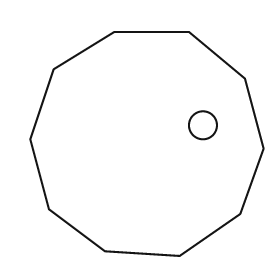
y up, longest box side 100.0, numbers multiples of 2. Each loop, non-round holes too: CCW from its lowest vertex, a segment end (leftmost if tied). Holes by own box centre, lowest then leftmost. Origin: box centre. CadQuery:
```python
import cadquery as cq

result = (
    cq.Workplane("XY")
    .moveTo(14.0, -48.0)
    .lineTo(40.0, -30.0)
    .lineTo(50.0, -2.0)
    .lineTo(42.0, 28.0)
    .lineTo(18.0, 48.0)
    .lineTo(-14.0, 48.0)
    .lineTo(-40.0, 32.0)
    .lineTo(-50.0, 2.0)
    .lineTo(-42.0, -28.0)
    .lineTo(-18.0, -46.0)
    .close()
    .moveTo(24.0, 8.0)
    .circle(6.0)
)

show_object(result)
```